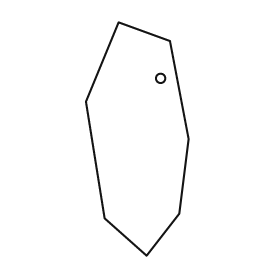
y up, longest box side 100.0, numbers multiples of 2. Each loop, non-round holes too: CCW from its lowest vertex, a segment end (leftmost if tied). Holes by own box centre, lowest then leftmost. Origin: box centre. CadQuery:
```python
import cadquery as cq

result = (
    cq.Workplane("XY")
    .moveTo(4.0, -50.0)
    .lineTo(18.0, -32.0)
    .lineTo(22.0, 0.0)
    .lineTo(14.0, 42.0)
    .lineTo(-8.0, 50.0)
    .lineTo(-22.0, 16.0)
    .lineTo(-14.0, -34.0)
    .close()
    .moveTo(10.0, 26.0)
    .circle(2.0)
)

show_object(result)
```